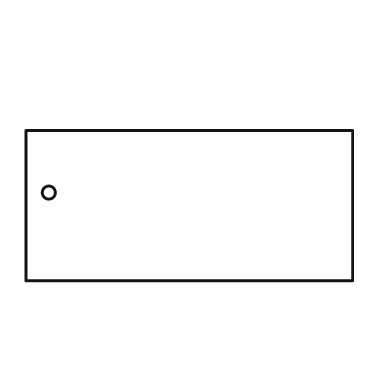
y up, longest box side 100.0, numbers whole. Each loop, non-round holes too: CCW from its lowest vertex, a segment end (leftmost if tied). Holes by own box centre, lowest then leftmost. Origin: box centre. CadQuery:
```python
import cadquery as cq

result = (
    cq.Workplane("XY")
    .moveTo(-50.0, -23.0)
    .lineTo(50.0, -23.0)
    .lineTo(50.0, 23.0)
    .lineTo(-50.0, 23.0)
    .close()
    .moveTo(-43.0, 4.0)
    .circle(2.0)
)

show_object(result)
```